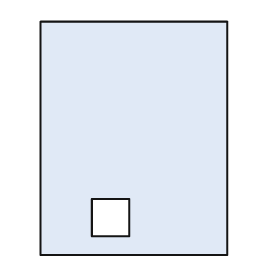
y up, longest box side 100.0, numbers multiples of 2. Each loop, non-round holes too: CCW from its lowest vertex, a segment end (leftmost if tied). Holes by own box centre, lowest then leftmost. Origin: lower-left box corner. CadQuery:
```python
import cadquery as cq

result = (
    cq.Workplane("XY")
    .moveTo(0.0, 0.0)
    .lineTo(80.0, 0.0)
    .lineTo(80.0, 100.0)
    .lineTo(0.0, 100.0)
    .close()
    .moveTo(22.0, 8.0)
    .lineTo(38.0, 8.0)
    .lineTo(38.0, 24.0)
    .lineTo(22.0, 24.0)
    .close()
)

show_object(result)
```